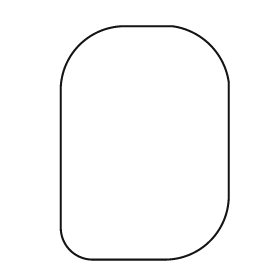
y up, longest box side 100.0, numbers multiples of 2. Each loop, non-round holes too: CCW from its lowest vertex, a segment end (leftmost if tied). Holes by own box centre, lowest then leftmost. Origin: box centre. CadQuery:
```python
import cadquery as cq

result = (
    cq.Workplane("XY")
    .moveTo(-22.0, -50.0)
    .lineTo(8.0, -50.0)
    .threePointArc((28.0, -42.0), (36.0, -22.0))
    .lineTo(36.0, 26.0)
    .threePointArc((28.0, 42.0), (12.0, 50.0))
    .lineTo(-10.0, 50.0)
    .threePointArc((-28.0, 42.0), (-36.0, 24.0))
    .lineTo(-36.0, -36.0)
    .threePointArc((-32.0, -46.0), (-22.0, -50.0))
    .close()
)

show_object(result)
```